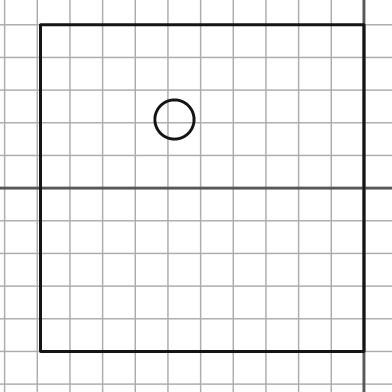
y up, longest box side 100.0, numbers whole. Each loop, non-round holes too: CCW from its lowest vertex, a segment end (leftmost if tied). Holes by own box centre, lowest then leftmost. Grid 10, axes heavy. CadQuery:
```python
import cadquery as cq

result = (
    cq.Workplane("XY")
    .moveTo(-99.0, -50.0)
    .lineTo(0.0, -50.0)
    .lineTo(0.0, 50.0)
    .lineTo(-99.0, 50.0)
    .close()
    .moveTo(-58.0, 21.0)
    .circle(6.0)
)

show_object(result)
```